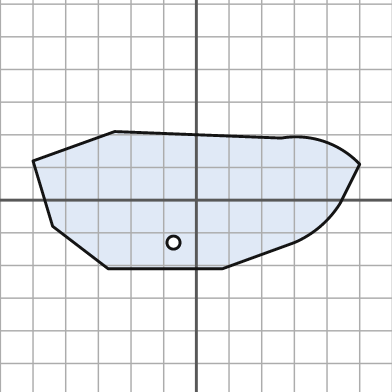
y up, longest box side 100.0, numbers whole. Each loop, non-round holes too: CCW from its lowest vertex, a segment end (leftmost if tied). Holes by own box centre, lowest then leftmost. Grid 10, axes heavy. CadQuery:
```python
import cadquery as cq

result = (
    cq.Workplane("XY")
    .moveTo(-27.0, -21.0)
    .lineTo(8.0, -21.0)
    .lineTo(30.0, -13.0)
    .threePointArc((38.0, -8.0), (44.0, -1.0))
    .lineTo(50.0, 11.0)
    .threePointArc((39.0, 18.0), (26.0, 19.0))
    .lineTo(-25.0, 21.0)
    .lineTo(-50.0, 12.0)
    .lineTo(-44.0, -8.0)
    .close()
    .moveTo(-7.0, -13.0)
    .circle(2.0)
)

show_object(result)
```